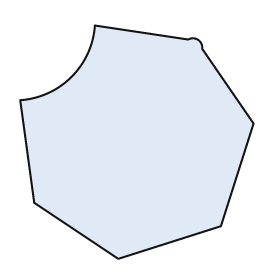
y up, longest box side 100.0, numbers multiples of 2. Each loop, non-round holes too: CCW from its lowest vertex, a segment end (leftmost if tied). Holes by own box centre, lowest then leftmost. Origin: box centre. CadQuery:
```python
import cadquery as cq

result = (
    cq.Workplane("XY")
    .moveTo(-8.0, -50.0)
    .lineTo(36.0, -36.0)
    .lineTo(50.0, 8.0)
    .lineTo(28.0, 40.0)
    .threePointArc((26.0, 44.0), (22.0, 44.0))
    .lineTo(-18.0, 50.0)
    .threePointArc((-28.0, 28.0), (-50.0, 18.0))
    .lineTo(-44.0, -26.0)
    .close()
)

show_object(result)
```